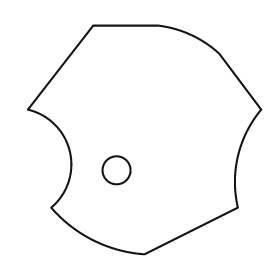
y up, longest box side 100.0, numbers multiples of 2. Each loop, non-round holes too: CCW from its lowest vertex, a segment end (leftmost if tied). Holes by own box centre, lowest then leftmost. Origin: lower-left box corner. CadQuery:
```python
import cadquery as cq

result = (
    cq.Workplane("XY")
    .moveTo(50.0, 0.0)
    .lineTo(90.0, 20.0)
    .threePointArc((90.0, 42.0), (100.0, 62.0))
    .lineTo(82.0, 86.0)
    .threePointArc((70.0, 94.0), (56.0, 98.0))
    .lineTo(28.0, 98.0)
    .lineTo(0.0, 62.0)
    .threePointArc((18.0, 44.0), (10.0, 20.0))
    .threePointArc((28.0, 6.0), (50.0, 0.0))
    .close()
    .moveTo(38.0, 36.0)
    .circle(6.0)
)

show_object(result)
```